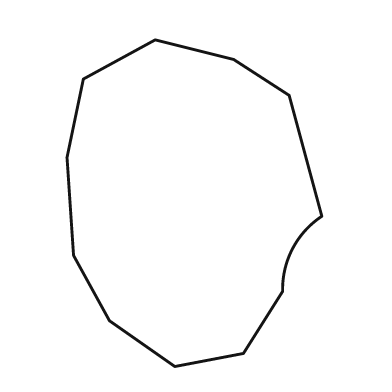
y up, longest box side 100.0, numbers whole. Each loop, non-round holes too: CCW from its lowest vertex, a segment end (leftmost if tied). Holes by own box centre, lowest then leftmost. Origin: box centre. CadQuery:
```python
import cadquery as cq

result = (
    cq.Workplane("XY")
    .moveTo(-6.0, -50.0)
    .lineTo(15.0, -46.0)
    .lineTo(27.0, -27.0)
    .threePointArc((30.0, -14.0), (39.0, -4.0))
    .lineTo(29.0, 33.0)
    .lineTo(12.0, 44.0)
    .lineTo(-12.0, 50.0)
    .lineTo(-34.0, 38.0)
    .lineTo(-39.0, 14.0)
    .lineTo(-37.0, -16.0)
    .lineTo(-26.0, -36.0)
    .close()
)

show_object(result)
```